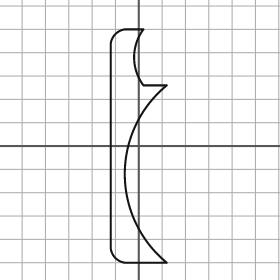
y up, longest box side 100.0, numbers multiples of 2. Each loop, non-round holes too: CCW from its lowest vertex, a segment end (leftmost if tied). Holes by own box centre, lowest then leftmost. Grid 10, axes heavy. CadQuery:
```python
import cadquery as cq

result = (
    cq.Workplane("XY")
    .moveTo(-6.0, -50.0)
    .lineTo(12.0, -50.0)
    .threePointArc((-6.0, -12.0), (12.0, 26.0))
    .lineTo(2.0, 26.0)
    .threePointArc((-2.0, 38.0), (2.0, 50.0))
    .lineTo(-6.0, 50.0)
    .threePointArc((-10.0, 48.0), (-12.0, 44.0))
    .lineTo(-12.0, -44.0)
    .threePointArc((-10.0, -48.0), (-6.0, -50.0))
    .close()
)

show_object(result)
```